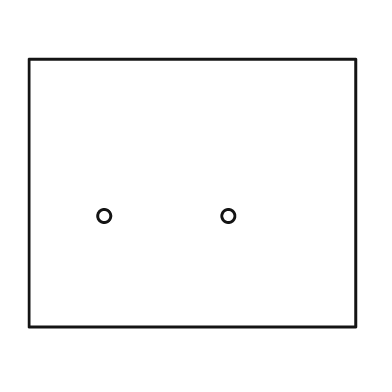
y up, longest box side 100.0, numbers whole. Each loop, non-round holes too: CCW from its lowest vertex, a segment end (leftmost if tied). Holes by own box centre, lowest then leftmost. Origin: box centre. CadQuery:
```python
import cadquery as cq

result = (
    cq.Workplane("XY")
    .moveTo(-50.0, -41.0)
    .lineTo(50.0, -41.0)
    .lineTo(50.0, 41.0)
    .lineTo(-50.0, 41.0)
    .close()
    .moveTo(-27.0, -7.0)
    .circle(2.0)
    .moveTo(11.0, -7.0)
    .circle(2.0)
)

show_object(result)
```